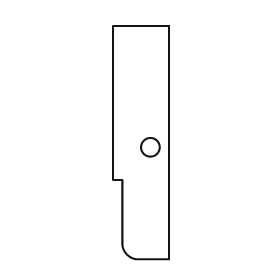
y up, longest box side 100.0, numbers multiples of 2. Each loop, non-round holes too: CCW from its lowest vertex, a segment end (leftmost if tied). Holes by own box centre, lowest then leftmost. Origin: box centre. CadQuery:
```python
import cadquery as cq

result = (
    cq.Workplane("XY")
    .moveTo(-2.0, -50.0)
    .lineTo(12.0, -50.0)
    .lineTo(12.0, 50.0)
    .lineTo(-12.0, 50.0)
    .lineTo(-12.0, -16.0)
    .lineTo(-8.0, -16.0)
    .lineTo(-8.0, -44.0)
    .threePointArc((-6.0, -48.0), (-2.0, -50.0))
    .close()
    .moveTo(4.0, -2.0)
    .circle(4.0)
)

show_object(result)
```